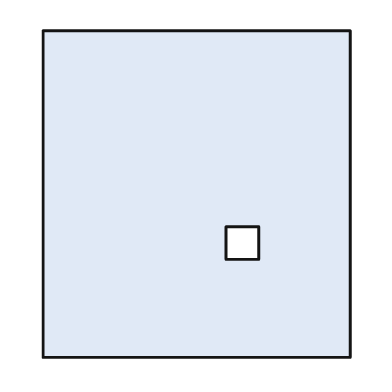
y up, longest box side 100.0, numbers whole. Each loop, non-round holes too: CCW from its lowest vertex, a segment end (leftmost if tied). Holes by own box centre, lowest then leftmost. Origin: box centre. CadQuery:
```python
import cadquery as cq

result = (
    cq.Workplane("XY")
    .moveTo(-47.0, -50.0)
    .lineTo(47.0, -50.0)
    .lineTo(47.0, 50.0)
    .lineTo(-47.0, 50.0)
    .close()
    .moveTo(9.0, -20.0)
    .lineTo(19.0, -20.0)
    .lineTo(19.0, -10.0)
    .lineTo(9.0, -10.0)
    .close()
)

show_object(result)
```